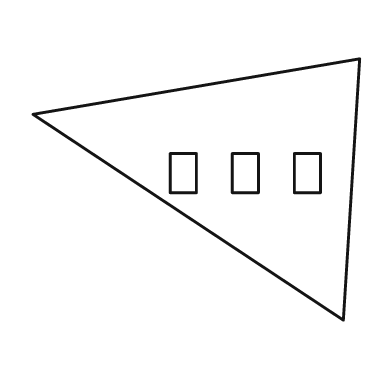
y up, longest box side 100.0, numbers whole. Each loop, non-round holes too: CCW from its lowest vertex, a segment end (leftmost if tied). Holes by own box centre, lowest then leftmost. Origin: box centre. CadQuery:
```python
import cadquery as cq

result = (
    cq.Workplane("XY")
    .moveTo(45.0, -40.0)
    .lineTo(50.0, 40.0)
    .lineTo(-50.0, 23.0)
    .close()
    .moveTo(-8.0, -1.0)
    .lineTo(0.0, -1.0)
    .lineTo(0.0, 11.0)
    .lineTo(-8.0, 11.0)
    .close()
    .moveTo(11.0, -1.0)
    .lineTo(19.0, -1.0)
    .lineTo(19.0, 11.0)
    .lineTo(11.0, 11.0)
    .close()
    .moveTo(30.0, -1.0)
    .lineTo(38.0, -1.0)
    .lineTo(38.0, 11.0)
    .lineTo(30.0, 11.0)
    .close()
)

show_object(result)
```